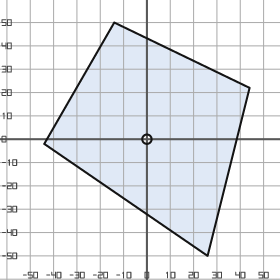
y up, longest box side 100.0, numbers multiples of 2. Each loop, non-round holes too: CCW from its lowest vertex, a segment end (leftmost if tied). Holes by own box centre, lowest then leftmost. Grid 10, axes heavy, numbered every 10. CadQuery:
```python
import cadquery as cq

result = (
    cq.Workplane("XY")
    .moveTo(26.0, -50.0)
    .lineTo(44.0, 22.0)
    .lineTo(-14.0, 50.0)
    .lineTo(-44.0, -2.0)
    .close()
    .moveTo(0.0, 0.0)
    .circle(2.0)
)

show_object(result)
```